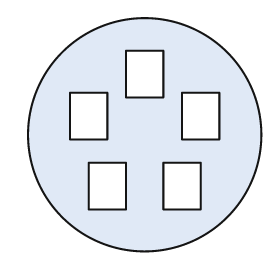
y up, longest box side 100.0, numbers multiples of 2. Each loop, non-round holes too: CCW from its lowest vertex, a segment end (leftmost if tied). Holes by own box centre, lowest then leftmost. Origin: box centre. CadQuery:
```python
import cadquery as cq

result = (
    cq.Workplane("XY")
    .moveTo(0.0, 0.0)
    .circle(50.0)
    .moveTo(-24.0, -32.0)
    .lineTo(-8.0, -32.0)
    .lineTo(-8.0, -12.0)
    .lineTo(-24.0, -12.0)
    .close()
    .moveTo(8.0, -32.0)
    .lineTo(24.0, -32.0)
    .lineTo(24.0, -12.0)
    .lineTo(8.0, -12.0)
    .close()
    .moveTo(-32.0, -2.0)
    .lineTo(-16.0, -2.0)
    .lineTo(-16.0, 18.0)
    .lineTo(-32.0, 18.0)
    .close()
    .moveTo(16.0, -2.0)
    .lineTo(32.0, -2.0)
    .lineTo(32.0, 18.0)
    .lineTo(16.0, 18.0)
    .close()
    .moveTo(-8.0, 16.0)
    .lineTo(8.0, 16.0)
    .lineTo(8.0, 36.0)
    .lineTo(-8.0, 36.0)
    .close()
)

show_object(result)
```